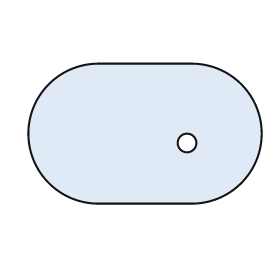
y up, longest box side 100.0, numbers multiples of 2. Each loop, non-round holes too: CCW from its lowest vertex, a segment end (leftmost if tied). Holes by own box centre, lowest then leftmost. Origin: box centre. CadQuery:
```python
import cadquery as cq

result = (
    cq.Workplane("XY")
    .moveTo(-20.0, -30.0)
    .lineTo(20.0, -30.0)
    .threePointArc((50.0, 0.0), (20.0, 30.0))
    .lineTo(-20.0, 30.0)
    .threePointArc((-50.0, 0.0), (-20.0, -30.0))
    .close()
    .moveTo(18.0, -4.0)
    .circle(4.0)
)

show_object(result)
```